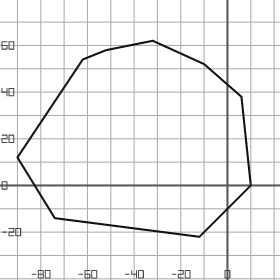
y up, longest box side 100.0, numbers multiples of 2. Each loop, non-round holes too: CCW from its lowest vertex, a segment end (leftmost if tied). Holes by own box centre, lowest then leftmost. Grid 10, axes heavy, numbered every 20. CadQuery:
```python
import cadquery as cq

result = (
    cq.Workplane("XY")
    .moveTo(-12.0, -22.0)
    .lineTo(10.0, 0.0)
    .lineTo(6.0, 38.0)
    .lineTo(-10.0, 52.0)
    .lineTo(-32.0, 62.0)
    .lineTo(-52.0, 58.0)
    .lineTo(-62.0, 54.0)
    .lineTo(-90.0, 12.0)
    .lineTo(-74.0, -14.0)
    .close()
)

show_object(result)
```